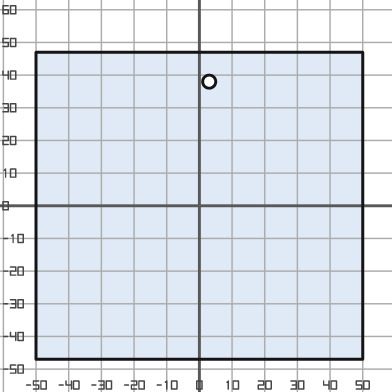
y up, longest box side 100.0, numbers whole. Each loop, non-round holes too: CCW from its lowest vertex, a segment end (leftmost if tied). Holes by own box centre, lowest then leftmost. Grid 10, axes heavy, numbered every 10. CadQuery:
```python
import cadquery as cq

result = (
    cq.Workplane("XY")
    .moveTo(-50.0, -47.0)
    .lineTo(50.0, -47.0)
    .lineTo(50.0, 47.0)
    .lineTo(-50.0, 47.0)
    .close()
    .moveTo(3.0, 38.0)
    .circle(2.0)
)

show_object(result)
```